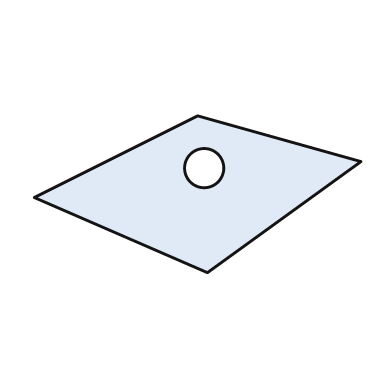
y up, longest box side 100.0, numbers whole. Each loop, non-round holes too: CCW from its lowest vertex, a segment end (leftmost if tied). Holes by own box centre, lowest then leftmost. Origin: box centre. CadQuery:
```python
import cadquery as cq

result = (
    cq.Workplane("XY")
    .moveTo(3.0, -24.0)
    .lineTo(50.0, 10.0)
    .lineTo(0.0, 24.0)
    .lineTo(-50.0, -1.0)
    .close()
    .moveTo(2.0, 8.0)
    .circle(6.0)
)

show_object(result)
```